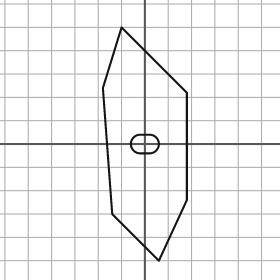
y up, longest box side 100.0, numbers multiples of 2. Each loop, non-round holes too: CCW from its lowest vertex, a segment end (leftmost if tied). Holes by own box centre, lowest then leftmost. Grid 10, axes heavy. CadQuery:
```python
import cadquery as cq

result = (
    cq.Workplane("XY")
    .moveTo(6.0, -50.0)
    .lineTo(18.0, -24.0)
    .lineTo(18.0, 22.0)
    .lineTo(-10.0, 50.0)
    .lineTo(-18.0, 24.0)
    .lineTo(-14.0, -30.0)
    .close()
    .moveTo(-2.0, -4.0)
    .lineTo(2.0, -4.0)
    .threePointArc((6.0, 0.0), (2.0, 4.0))
    .lineTo(-2.0, 4.0)
    .threePointArc((-6.0, 0.0), (-2.0, -4.0))
    .close()
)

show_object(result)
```